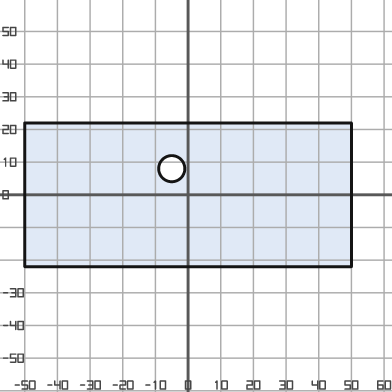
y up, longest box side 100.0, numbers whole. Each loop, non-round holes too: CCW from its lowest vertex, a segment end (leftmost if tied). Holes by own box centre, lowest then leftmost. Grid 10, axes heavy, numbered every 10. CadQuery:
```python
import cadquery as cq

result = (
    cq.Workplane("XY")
    .moveTo(-50.0, -22.0)
    .lineTo(50.0, -22.0)
    .lineTo(50.0, 22.0)
    .lineTo(-50.0, 22.0)
    .close()
    .moveTo(-5.0, 8.0)
    .circle(4.0)
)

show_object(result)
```